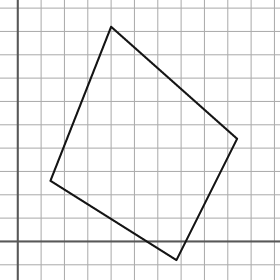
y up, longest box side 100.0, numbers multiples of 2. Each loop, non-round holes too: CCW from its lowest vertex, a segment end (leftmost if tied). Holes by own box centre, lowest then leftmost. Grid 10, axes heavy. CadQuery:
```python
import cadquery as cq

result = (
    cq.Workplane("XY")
    .moveTo(68.0, -8.0)
    .lineTo(94.0, 44.0)
    .lineTo(40.0, 92.0)
    .lineTo(14.0, 26.0)
    .close()
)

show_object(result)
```